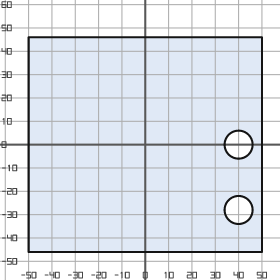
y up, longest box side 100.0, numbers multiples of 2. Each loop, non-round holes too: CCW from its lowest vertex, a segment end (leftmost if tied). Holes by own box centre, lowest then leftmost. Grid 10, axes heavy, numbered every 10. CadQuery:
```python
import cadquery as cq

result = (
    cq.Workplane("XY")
    .moveTo(-50.0, -46.0)
    .lineTo(50.0, -46.0)
    .lineTo(50.0, 46.0)
    .lineTo(-50.0, 46.0)
    .close()
    .moveTo(40.0, -28.0)
    .circle(6.0)
    .moveTo(40.0, 0.0)
    .circle(6.0)
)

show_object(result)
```